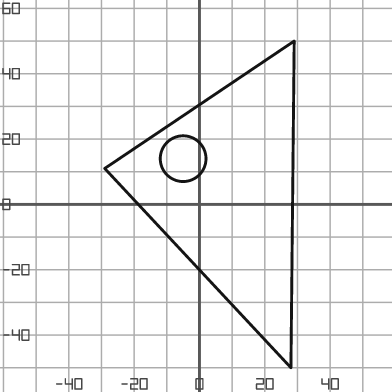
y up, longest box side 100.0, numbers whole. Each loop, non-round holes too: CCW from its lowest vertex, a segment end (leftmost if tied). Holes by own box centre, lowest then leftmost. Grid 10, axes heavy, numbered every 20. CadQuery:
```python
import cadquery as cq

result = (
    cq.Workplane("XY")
    .moveTo(28.0, -50.0)
    .lineTo(29.0, 50.0)
    .lineTo(-29.0, 11.0)
    .close()
    .moveTo(-5.0, 14.0)
    .circle(7.0)
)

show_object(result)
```